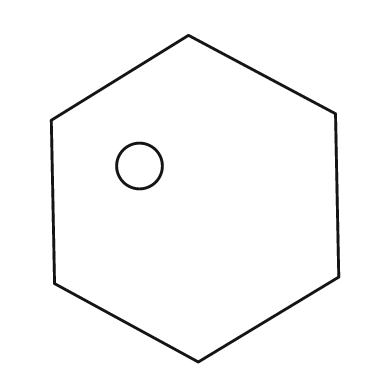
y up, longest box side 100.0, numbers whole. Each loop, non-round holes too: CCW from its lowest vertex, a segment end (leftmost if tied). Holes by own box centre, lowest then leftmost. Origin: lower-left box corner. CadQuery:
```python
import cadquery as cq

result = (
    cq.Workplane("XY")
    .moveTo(45.0, 0.0)
    .lineTo(88.0, 26.0)
    .lineTo(87.0, 76.0)
    .lineTo(42.0, 100.0)
    .lineTo(0.0, 74.0)
    .lineTo(1.0, 24.0)
    .close()
    .moveTo(27.0, 60.0)
    .circle(7.0)
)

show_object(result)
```